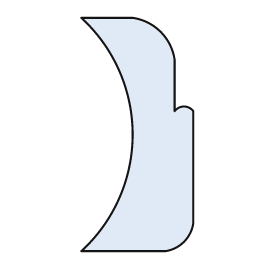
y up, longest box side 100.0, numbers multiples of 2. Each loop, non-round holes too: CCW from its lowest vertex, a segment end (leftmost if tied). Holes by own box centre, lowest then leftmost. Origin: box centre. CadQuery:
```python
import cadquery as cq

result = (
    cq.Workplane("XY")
    .moveTo(-24.0, -50.0)
    .lineTo(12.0, -50.0)
    .threePointArc((20.0, -46.0), (24.0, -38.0))
    .lineTo(24.0, 10.0)
    .threePointArc((20.0, 12.0), (16.0, 10.0))
    .lineTo(16.0, 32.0)
    .threePointArc((10.0, 44.0), (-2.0, 50.0))
    .lineTo(-24.0, 50.0)
    .threePointArc((-2.0, 0.0), (-24.0, -50.0))
    .close()
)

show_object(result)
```